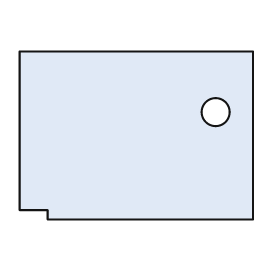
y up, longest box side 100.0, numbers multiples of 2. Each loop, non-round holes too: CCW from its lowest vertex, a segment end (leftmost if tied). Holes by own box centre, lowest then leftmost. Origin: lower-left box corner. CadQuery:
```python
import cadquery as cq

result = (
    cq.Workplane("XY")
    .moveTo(12.0, 0.0)
    .lineTo(100.0, 0.0)
    .lineTo(100.0, 72.0)
    .lineTo(0.0, 72.0)
    .lineTo(0.0, 4.0)
    .lineTo(12.0, 4.0)
    .close()
    .moveTo(84.0, 46.0)
    .circle(6.0)
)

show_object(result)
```